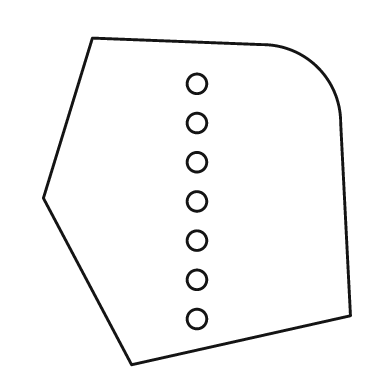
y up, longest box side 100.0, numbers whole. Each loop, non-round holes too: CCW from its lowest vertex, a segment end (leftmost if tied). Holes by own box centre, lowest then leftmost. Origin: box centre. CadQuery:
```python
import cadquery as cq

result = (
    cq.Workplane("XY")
    .moveTo(-20.0, -50.0)
    .lineTo(47.0, -35.0)
    .lineTo(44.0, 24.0)
    .threePointArc((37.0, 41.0), (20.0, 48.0))
    .lineTo(-32.0, 50.0)
    .lineTo(-47.0, 1.0)
    .close()
    .moveTo(0.0, -36.0)
    .circle(3.0)
    .moveTo(0.0, -24.0)
    .circle(3.0)
    .moveTo(0.0, -12.0)
    .circle(3.0)
    .moveTo(0.0, 0.0)
    .circle(3.0)
    .moveTo(0.0, 12.0)
    .circle(3.0)
    .moveTo(0.0, 24.0)
    .circle(3.0)
    .moveTo(0.0, 36.0)
    .circle(3.0)
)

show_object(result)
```